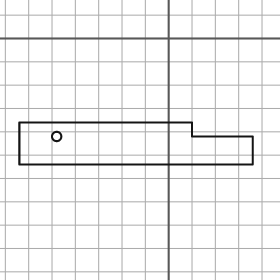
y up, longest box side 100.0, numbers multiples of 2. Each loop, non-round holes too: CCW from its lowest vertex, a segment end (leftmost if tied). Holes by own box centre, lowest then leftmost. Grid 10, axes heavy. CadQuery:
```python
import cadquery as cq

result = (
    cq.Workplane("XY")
    .moveTo(-64.0, -54.0)
    .lineTo(36.0, -54.0)
    .lineTo(36.0, -42.0)
    .lineTo(10.0, -42.0)
    .lineTo(10.0, -36.0)
    .lineTo(-64.0, -36.0)
    .close()
    .moveTo(-48.0, -42.0)
    .circle(2.0)
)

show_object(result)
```